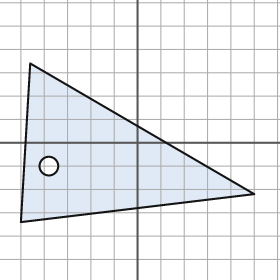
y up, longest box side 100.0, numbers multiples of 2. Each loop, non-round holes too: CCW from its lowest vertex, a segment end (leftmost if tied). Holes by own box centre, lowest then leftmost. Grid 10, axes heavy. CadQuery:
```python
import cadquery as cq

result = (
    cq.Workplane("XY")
    .moveTo(-50.0, -34.0)
    .lineTo(50.0, -22.0)
    .lineTo(-46.0, 34.0)
    .close()
    .moveTo(-38.0, -10.0)
    .circle(4.0)
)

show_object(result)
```